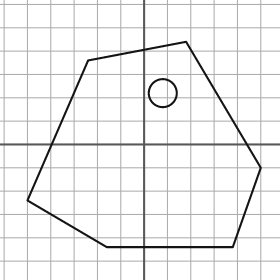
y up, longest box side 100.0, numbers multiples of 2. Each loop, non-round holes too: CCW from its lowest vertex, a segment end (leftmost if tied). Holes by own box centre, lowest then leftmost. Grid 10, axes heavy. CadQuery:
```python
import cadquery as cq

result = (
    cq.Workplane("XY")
    .moveTo(-16.0, -44.0)
    .lineTo(38.0, -44.0)
    .lineTo(50.0, -10.0)
    .lineTo(18.0, 44.0)
    .lineTo(-24.0, 36.0)
    .lineTo(-50.0, -24.0)
    .close()
    .moveTo(8.0, 22.0)
    .circle(6.0)
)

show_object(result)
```